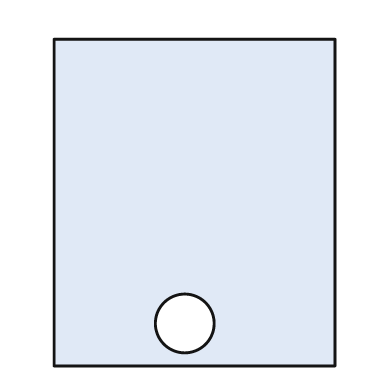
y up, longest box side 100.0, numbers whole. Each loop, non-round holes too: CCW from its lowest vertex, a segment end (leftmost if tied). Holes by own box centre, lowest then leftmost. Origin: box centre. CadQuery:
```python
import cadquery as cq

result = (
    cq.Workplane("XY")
    .moveTo(-43.0, -50.0)
    .lineTo(43.0, -50.0)
    .lineTo(43.0, 50.0)
    .lineTo(-43.0, 50.0)
    .close()
    .moveTo(-3.0, -37.0)
    .circle(9.0)
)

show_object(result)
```